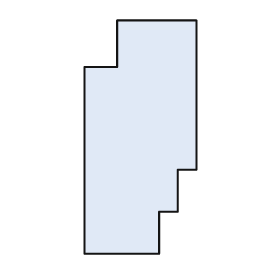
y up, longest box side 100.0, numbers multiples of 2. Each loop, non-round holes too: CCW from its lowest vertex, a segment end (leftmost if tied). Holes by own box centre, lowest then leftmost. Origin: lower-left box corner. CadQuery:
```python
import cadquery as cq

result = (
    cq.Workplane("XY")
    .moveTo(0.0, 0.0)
    .lineTo(32.0, 0.0)
    .lineTo(32.0, 18.0)
    .lineTo(40.0, 18.0)
    .lineTo(40.0, 36.0)
    .lineTo(48.0, 36.0)
    .lineTo(48.0, 100.0)
    .lineTo(14.0, 100.0)
    .lineTo(14.0, 80.0)
    .lineTo(0.0, 80.0)
    .close()
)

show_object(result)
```